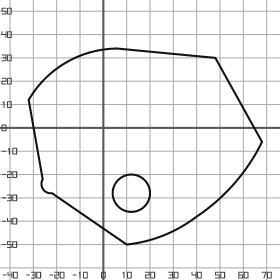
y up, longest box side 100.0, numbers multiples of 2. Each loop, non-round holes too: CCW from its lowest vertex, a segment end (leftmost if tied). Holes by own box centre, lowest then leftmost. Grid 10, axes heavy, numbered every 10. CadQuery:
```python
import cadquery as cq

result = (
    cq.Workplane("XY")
    .moveTo(10.0, -50.0)
    .threePointArc((26.0, -46.0), (40.0, -38.0))
    .threePointArc((56.0, -24.0), (68.0, -6.0))
    .lineTo(48.0, 30.0)
    .lineTo(6.0, 34.0)
    .threePointArc((-16.0, 28.0), (-32.0, 12.0))
    .lineTo(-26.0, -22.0)
    .threePointArc((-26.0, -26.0), (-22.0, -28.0))
    .close()
    .moveTo(12.0, -28.0)
    .circle(8.0)
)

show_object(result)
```